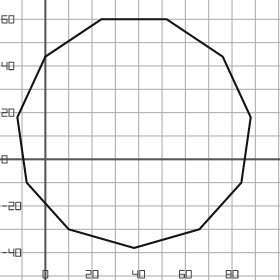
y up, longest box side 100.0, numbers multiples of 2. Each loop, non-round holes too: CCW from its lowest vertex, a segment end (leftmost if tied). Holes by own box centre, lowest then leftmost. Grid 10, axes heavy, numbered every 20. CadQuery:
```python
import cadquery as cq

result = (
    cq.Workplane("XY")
    .moveTo(38.0, -38.0)
    .lineTo(66.0, -30.0)
    .lineTo(84.0, -10.0)
    .lineTo(88.0, 18.0)
    .lineTo(76.0, 44.0)
    .lineTo(52.0, 60.0)
    .lineTo(24.0, 60.0)
    .lineTo(0.0, 44.0)
    .lineTo(-12.0, 18.0)
    .lineTo(-8.0, -10.0)
    .lineTo(10.0, -30.0)
    .close()
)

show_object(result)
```